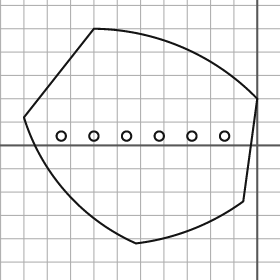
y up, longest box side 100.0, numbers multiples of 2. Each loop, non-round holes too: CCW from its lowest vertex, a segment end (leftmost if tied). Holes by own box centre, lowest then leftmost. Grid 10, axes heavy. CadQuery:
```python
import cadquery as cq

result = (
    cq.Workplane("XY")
    .moveTo(-52.0, -42.0)
    .threePointArc((-28.0, -36.0), (-6.0, -24.0))
    .lineTo(0.0, 20.0)
    .threePointArc((-32.0, 42.0), (-70.0, 50.0))
    .lineTo(-100.0, 12.0)
    .threePointArc((-82.0, -20.0), (-52.0, -42.0))
    .close()
    .moveTo(-84.0, 4.0)
    .circle(2.0)
    .moveTo(-70.0, 4.0)
    .circle(2.0)
    .moveTo(-56.0, 4.0)
    .circle(2.0)
    .moveTo(-42.0, 4.0)
    .circle(2.0)
    .moveTo(-28.0, 4.0)
    .circle(2.0)
    .moveTo(-14.0, 4.0)
    .circle(2.0)
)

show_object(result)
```